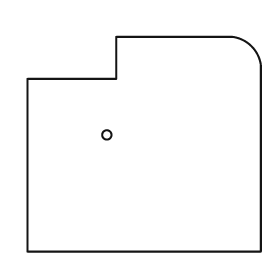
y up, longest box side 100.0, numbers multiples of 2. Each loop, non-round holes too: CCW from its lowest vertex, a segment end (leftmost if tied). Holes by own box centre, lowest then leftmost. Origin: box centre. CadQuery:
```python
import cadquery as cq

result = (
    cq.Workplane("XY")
    .moveTo(-50.0, -46.0)
    .lineTo(50.0, -46.0)
    .lineTo(50.0, 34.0)
    .threePointArc((46.0, 42.0), (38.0, 46.0))
    .lineTo(-12.0, 46.0)
    .lineTo(-12.0, 28.0)
    .lineTo(-50.0, 28.0)
    .close()
    .moveTo(-16.0, 4.0)
    .circle(2.0)
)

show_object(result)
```